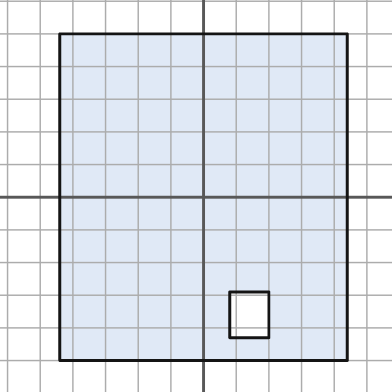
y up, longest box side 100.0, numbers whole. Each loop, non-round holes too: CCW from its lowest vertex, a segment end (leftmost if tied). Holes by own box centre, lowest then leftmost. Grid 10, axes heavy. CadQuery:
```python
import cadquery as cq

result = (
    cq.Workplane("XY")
    .moveTo(-44.0, -50.0)
    .lineTo(44.0, -50.0)
    .lineTo(44.0, 50.0)
    .lineTo(-44.0, 50.0)
    .close()
    .moveTo(8.0, -43.0)
    .lineTo(20.0, -43.0)
    .lineTo(20.0, -29.0)
    .lineTo(8.0, -29.0)
    .close()
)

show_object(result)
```